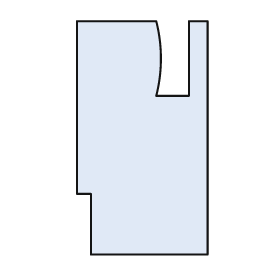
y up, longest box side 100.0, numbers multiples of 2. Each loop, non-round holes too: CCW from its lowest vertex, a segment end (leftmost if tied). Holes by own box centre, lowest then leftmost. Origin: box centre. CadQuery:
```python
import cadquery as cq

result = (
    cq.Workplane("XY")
    .moveTo(-22.0, -50.0)
    .lineTo(28.0, -50.0)
    .lineTo(28.0, 50.0)
    .lineTo(20.0, 50.0)
    .lineTo(20.0, 18.0)
    .lineTo(6.0, 18.0)
    .threePointArc((8.0, 34.0), (6.0, 50.0))
    .lineTo(-28.0, 50.0)
    .lineTo(-28.0, -24.0)
    .lineTo(-22.0, -24.0)
    .close()
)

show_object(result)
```